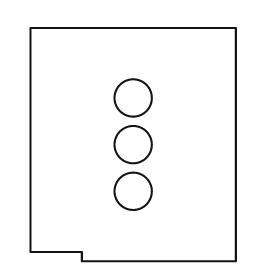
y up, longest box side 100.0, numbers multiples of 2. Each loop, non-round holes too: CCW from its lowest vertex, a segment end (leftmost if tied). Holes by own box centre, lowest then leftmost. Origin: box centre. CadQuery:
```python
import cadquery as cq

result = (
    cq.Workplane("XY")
    .moveTo(-22.0, -50.0)
    .lineTo(44.0, -50.0)
    .lineTo(44.0, 50.0)
    .lineTo(-44.0, 50.0)
    .lineTo(-44.0, -46.0)
    .lineTo(-22.0, -46.0)
    .close()
    .moveTo(0.0, -20.0)
    .circle(8.0)
    .moveTo(0.0, 0.0)
    .circle(8.0)
    .moveTo(0.0, 20.0)
    .circle(8.0)
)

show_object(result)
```